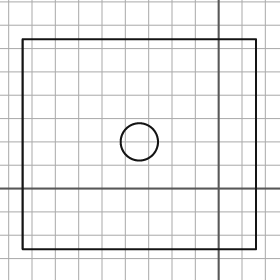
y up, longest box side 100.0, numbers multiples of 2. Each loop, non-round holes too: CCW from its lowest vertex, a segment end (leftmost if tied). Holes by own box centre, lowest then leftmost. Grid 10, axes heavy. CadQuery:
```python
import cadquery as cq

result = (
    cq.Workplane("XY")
    .moveTo(-84.0, -26.0)
    .lineTo(16.0, -26.0)
    .lineTo(16.0, 64.0)
    .lineTo(-84.0, 64.0)
    .close()
    .moveTo(-34.0, 20.0)
    .circle(8.0)
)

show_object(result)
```